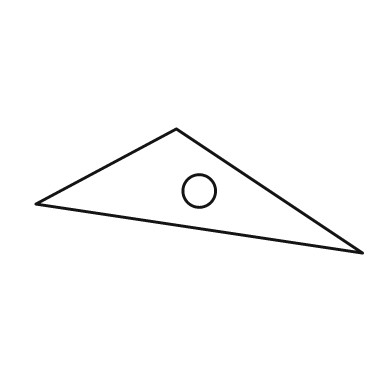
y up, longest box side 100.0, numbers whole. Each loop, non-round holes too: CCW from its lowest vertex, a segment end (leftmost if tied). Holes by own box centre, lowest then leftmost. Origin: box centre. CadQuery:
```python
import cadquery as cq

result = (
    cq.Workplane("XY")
    .moveTo(50.0, -19.0)
    .lineTo(-7.0, 19.0)
    .lineTo(-50.0, -4.0)
    .close()
    .moveTo(0.0, 0.0)
    .circle(5.0)
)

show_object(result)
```